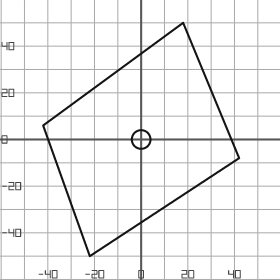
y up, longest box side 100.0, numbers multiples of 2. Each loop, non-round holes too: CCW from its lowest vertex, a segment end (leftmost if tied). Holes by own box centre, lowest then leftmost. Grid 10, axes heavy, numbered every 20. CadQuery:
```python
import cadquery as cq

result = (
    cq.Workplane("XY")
    .moveTo(-22.0, -50.0)
    .lineTo(42.0, -8.0)
    .lineTo(18.0, 50.0)
    .lineTo(-42.0, 6.0)
    .close()
    .moveTo(0.0, 0.0)
    .circle(4.0)
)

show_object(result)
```